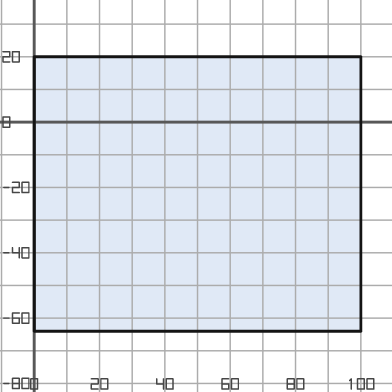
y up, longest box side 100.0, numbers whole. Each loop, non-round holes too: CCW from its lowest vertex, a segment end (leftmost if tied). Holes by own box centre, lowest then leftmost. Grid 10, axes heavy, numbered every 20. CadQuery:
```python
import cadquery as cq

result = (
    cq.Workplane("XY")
    .moveTo(0.0, -64.0)
    .lineTo(100.0, -64.0)
    .lineTo(100.0, 20.0)
    .lineTo(0.0, 20.0)
    .close()
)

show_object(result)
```